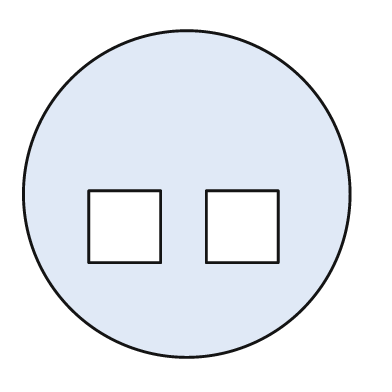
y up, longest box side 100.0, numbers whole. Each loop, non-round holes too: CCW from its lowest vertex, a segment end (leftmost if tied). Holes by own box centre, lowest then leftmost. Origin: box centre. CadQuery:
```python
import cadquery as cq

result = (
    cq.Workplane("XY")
    .moveTo(0.0, 0.0)
    .circle(50.0)
    .moveTo(-30.0, -21.0)
    .lineTo(-8.0, -21.0)
    .lineTo(-8.0, 1.0)
    .lineTo(-30.0, 1.0)
    .close()
    .moveTo(6.0, -21.0)
    .lineTo(28.0, -21.0)
    .lineTo(28.0, 1.0)
    .lineTo(6.0, 1.0)
    .close()
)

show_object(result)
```